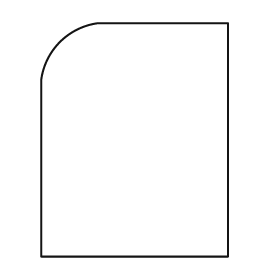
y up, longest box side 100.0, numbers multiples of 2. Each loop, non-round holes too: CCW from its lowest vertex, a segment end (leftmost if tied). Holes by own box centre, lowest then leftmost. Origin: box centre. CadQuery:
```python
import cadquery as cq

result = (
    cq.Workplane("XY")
    .moveTo(-40.0, -50.0)
    .lineTo(40.0, -50.0)
    .lineTo(40.0, 50.0)
    .lineTo(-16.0, 50.0)
    .threePointArc((-32.0, 42.0), (-40.0, 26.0))
    .close()
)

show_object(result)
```